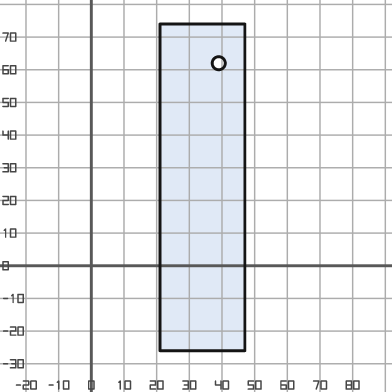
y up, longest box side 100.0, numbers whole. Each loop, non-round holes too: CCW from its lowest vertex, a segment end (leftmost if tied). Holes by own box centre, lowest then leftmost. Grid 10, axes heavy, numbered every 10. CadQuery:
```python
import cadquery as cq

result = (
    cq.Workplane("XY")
    .moveTo(21.0, -26.0)
    .lineTo(47.0, -26.0)
    .lineTo(47.0, 74.0)
    .lineTo(21.0, 74.0)
    .close()
    .moveTo(39.0, 62.0)
    .circle(2.0)
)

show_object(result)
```